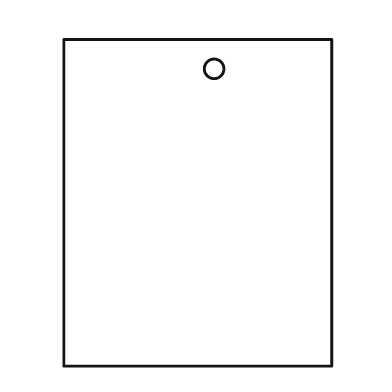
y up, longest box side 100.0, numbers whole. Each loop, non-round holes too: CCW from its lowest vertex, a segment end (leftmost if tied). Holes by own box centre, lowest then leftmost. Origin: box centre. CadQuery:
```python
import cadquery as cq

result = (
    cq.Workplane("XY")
    .moveTo(-41.0, -50.0)
    .lineTo(41.0, -50.0)
    .lineTo(41.0, 50.0)
    .lineTo(-41.0, 50.0)
    .close()
    .moveTo(5.0, 41.0)
    .circle(3.0)
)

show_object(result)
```